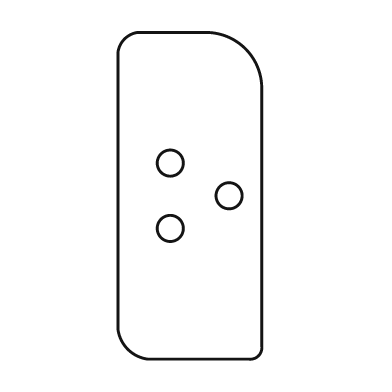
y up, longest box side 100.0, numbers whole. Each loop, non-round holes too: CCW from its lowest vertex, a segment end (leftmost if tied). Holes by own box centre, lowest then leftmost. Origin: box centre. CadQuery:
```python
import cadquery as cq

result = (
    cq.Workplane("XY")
    .moveTo(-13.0, -50.0)
    .lineTo(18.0, -50.0)
    .threePointArc((21.0, -49.0), (22.0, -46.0))
    .lineTo(22.0, 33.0)
    .threePointArc((17.0, 45.0), (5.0, 50.0))
    .lineTo(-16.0, 50.0)
    .threePointArc((-20.0, 48.0), (-22.0, 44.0))
    .lineTo(-22.0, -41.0)
    .threePointArc((-19.0, -47.0), (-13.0, -50.0))
    .close()
    .moveTo(-6.0, -10.0)
    .circle(4.0)
    .moveTo(12.0, 0.0)
    .circle(4.0)
    .moveTo(-6.0, 10.0)
    .circle(4.0)
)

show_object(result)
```